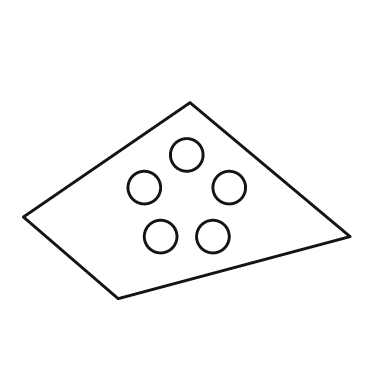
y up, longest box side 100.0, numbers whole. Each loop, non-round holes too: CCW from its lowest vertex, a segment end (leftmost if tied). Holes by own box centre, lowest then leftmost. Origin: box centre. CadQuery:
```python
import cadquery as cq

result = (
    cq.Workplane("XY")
    .moveTo(-21.0, -30.0)
    .lineTo(50.0, -11.0)
    .lineTo(1.0, 30.0)
    .lineTo(-50.0, -5.0)
    .close()
    .moveTo(-8.0, -11.0)
    .circle(5.0)
    .moveTo(8.0, -11.0)
    .circle(5.0)
    .moveTo(-13.0, 4.0)
    .circle(5.0)
    .moveTo(13.0, 4.0)
    .circle(5.0)
    .moveTo(0.0, 14.0)
    .circle(5.0)
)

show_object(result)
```